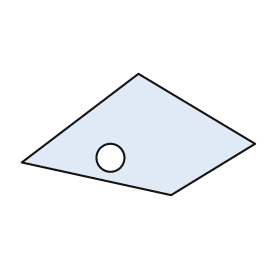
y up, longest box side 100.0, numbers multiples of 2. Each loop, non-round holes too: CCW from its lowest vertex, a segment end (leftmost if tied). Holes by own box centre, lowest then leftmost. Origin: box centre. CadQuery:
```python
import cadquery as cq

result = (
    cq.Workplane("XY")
    .moveTo(14.0, -26.0)
    .lineTo(50.0, -4.0)
    .lineTo(0.0, 26.0)
    .lineTo(-50.0, -12.0)
    .close()
    .moveTo(-12.0, -10.0)
    .circle(6.0)
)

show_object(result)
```